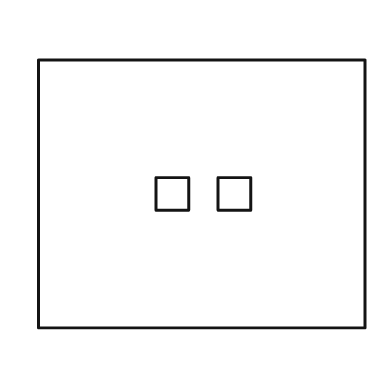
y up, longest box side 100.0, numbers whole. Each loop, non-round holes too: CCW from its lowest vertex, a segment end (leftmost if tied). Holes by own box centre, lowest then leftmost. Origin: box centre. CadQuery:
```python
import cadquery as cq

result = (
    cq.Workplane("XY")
    .moveTo(-50.0, -41.0)
    .lineTo(50.0, -41.0)
    .lineTo(50.0, 41.0)
    .lineTo(-50.0, 41.0)
    .close()
    .moveTo(-14.0, -5.0)
    .lineTo(-4.0, -5.0)
    .lineTo(-4.0, 5.0)
    .lineTo(-14.0, 5.0)
    .close()
    .moveTo(5.0, -5.0)
    .lineTo(15.0, -5.0)
    .lineTo(15.0, 5.0)
    .lineTo(5.0, 5.0)
    .close()
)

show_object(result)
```